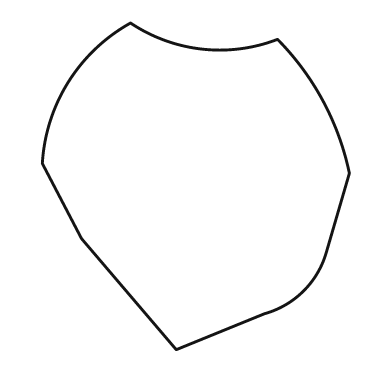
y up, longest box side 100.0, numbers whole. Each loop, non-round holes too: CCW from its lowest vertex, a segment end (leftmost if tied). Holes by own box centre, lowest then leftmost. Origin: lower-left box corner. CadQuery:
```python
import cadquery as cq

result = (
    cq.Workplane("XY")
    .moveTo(41.0, 0.0)
    .lineTo(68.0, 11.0)
    .threePointArc((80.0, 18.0), (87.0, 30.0))
    .lineTo(94.0, 54.0)
    .threePointArc((86.0, 76.0), (72.0, 95.0))
    .threePointArc((49.0, 92.0), (27.0, 100.0))
    .threePointArc((8.0, 82.0), (0.0, 57.0))
    .lineTo(12.0, 34.0)
    .close()
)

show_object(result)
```